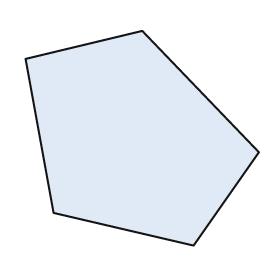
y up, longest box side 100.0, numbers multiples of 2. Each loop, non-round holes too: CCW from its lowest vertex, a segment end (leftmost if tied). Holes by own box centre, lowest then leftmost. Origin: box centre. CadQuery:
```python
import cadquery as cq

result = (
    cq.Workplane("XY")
    .moveTo(22.0, -46.0)
    .lineTo(50.0, -6.0)
    .lineTo(0.0, 46.0)
    .lineTo(-50.0, 34.0)
    .lineTo(-38.0, -32.0)
    .close()
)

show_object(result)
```